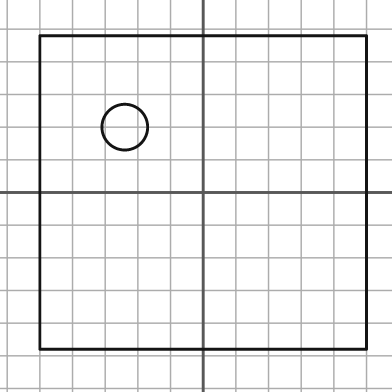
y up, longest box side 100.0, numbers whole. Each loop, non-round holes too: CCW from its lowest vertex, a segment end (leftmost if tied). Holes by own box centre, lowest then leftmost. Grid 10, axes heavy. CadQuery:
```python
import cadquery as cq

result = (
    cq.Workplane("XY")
    .moveTo(-50.0, -48.0)
    .lineTo(50.0, -48.0)
    .lineTo(50.0, 48.0)
    .lineTo(-50.0, 48.0)
    .close()
    .moveTo(-24.0, 20.0)
    .circle(7.0)
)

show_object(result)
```